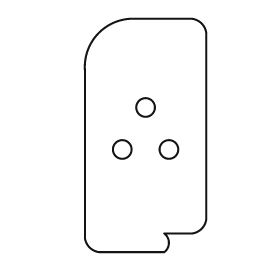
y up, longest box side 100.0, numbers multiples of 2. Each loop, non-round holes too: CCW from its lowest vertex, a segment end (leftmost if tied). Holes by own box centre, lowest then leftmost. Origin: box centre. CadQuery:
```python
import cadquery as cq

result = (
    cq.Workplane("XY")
    .moveTo(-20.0, -50.0)
    .lineTo(8.0, -50.0)
    .threePointArc((10.0, -46.0), (8.0, -42.0))
    .lineTo(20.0, -42.0)
    .threePointArc((24.0, -40.0), (26.0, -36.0))
    .lineTo(26.0, 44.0)
    .threePointArc((24.0, 48.0), (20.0, 50.0))
    .lineTo(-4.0, 50.0)
    .threePointArc((-20.0, 44.0), (-26.0, 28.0))
    .lineTo(-26.0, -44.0)
    .threePointArc((-24.0, -48.0), (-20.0, -50.0))
    .close()
    .moveTo(-10.0, -6.0)
    .circle(4.0)
    .moveTo(10.0, -6.0)
    .circle(4.0)
    .moveTo(0.0, 12.0)
    .circle(4.0)
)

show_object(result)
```